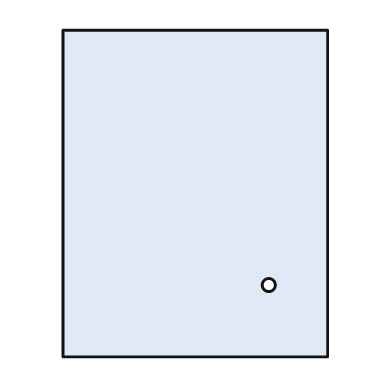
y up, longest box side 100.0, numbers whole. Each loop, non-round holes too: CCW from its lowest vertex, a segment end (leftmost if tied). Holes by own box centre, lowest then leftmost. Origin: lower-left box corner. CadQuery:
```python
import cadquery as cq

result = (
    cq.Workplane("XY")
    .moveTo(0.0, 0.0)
    .lineTo(81.0, 0.0)
    .lineTo(81.0, 100.0)
    .lineTo(0.0, 100.0)
    .close()
    .moveTo(63.0, 22.0)
    .circle(2.0)
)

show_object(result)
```